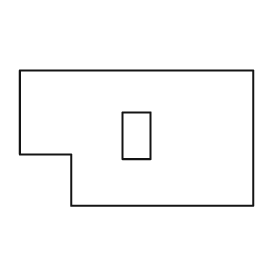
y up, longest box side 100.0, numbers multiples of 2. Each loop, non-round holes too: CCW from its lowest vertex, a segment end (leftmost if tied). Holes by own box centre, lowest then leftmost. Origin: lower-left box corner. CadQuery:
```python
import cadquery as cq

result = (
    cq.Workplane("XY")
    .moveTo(22.0, 0.0)
    .lineTo(100.0, 0.0)
    .lineTo(100.0, 58.0)
    .lineTo(0.0, 58.0)
    .lineTo(0.0, 22.0)
    .lineTo(22.0, 22.0)
    .close()
    .moveTo(44.0, 20.0)
    .lineTo(56.0, 20.0)
    .lineTo(56.0, 40.0)
    .lineTo(44.0, 40.0)
    .close()
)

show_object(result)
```